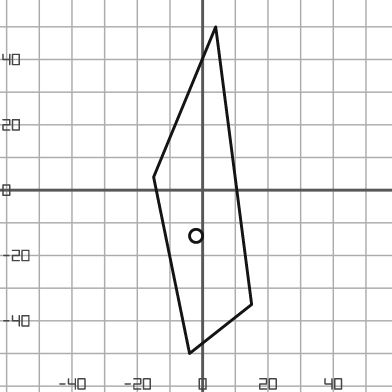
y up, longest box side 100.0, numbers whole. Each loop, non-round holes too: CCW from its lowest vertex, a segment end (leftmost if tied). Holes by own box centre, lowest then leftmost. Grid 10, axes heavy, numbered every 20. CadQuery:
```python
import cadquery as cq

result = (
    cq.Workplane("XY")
    .moveTo(-4.0, -50.0)
    .lineTo(15.0, -35.0)
    .lineTo(4.0, 50.0)
    .lineTo(-15.0, 4.0)
    .close()
    .moveTo(-2.0, -14.0)
    .circle(2.0)
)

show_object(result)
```